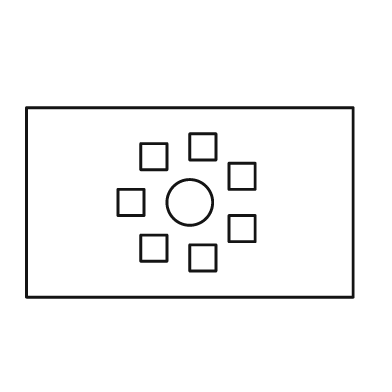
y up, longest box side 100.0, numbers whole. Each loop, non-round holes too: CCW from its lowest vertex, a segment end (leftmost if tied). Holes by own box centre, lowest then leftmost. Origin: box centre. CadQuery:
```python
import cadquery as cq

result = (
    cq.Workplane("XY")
    .moveTo(-50.0, -29.0)
    .lineTo(50.0, -29.0)
    .lineTo(50.0, 29.0)
    .lineTo(-50.0, 29.0)
    .close()
    .moveTo(0.0, -21.0)
    .lineTo(8.0, -21.0)
    .lineTo(8.0, -13.0)
    .lineTo(0.0, -13.0)
    .close()
    .moveTo(-15.0, -18.0)
    .lineTo(-7.0, -18.0)
    .lineTo(-7.0, -10.0)
    .lineTo(-15.0, -10.0)
    .close()
    .moveTo(12.0, -12.0)
    .lineTo(20.0, -12.0)
    .lineTo(20.0, -4.0)
    .lineTo(12.0, -4.0)
    .close()
    .moveTo(-22.0, -4.0)
    .lineTo(-14.0, -4.0)
    .lineTo(-14.0, 4.0)
    .lineTo(-22.0, 4.0)
    .close()
    .moveTo(0.0, 0.0)
    .circle(7.0)
    .moveTo(12.0, 4.0)
    .lineTo(20.0, 4.0)
    .lineTo(20.0, 12.0)
    .lineTo(12.0, 12.0)
    .close()
    .moveTo(-15.0, 10.0)
    .lineTo(-7.0, 10.0)
    .lineTo(-7.0, 18.0)
    .lineTo(-15.0, 18.0)
    .close()
    .moveTo(0.0, 13.0)
    .lineTo(8.0, 13.0)
    .lineTo(8.0, 21.0)
    .lineTo(0.0, 21.0)
    .close()
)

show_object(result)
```